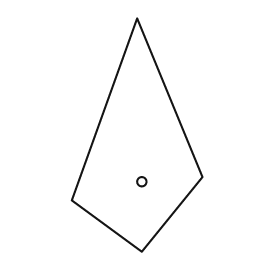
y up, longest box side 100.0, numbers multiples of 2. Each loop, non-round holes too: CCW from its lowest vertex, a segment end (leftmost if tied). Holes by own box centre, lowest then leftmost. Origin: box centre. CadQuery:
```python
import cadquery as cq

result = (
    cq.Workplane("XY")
    .moveTo(2.0, -50.0)
    .lineTo(28.0, -18.0)
    .lineTo(0.0, 50.0)
    .lineTo(-28.0, -28.0)
    .close()
    .moveTo(2.0, -20.0)
    .circle(2.0)
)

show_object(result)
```